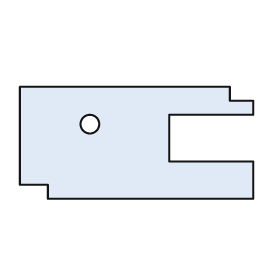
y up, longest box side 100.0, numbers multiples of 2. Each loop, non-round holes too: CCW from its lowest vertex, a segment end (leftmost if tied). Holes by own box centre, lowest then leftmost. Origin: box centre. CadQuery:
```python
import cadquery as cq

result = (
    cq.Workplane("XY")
    .moveTo(-38.0, -24.0)
    .lineTo(50.0, -24.0)
    .lineTo(50.0, -8.0)
    .lineTo(14.0, -8.0)
    .lineTo(14.0, 12.0)
    .lineTo(50.0, 12.0)
    .lineTo(50.0, 18.0)
    .lineTo(40.0, 18.0)
    .lineTo(40.0, 24.0)
    .lineTo(-50.0, 24.0)
    .lineTo(-50.0, -18.0)
    .lineTo(-38.0, -18.0)
    .close()
    .moveTo(-20.0, 8.0)
    .circle(4.0)
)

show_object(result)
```